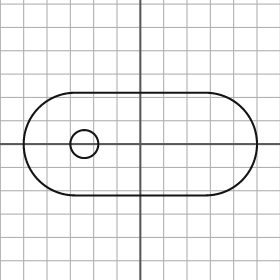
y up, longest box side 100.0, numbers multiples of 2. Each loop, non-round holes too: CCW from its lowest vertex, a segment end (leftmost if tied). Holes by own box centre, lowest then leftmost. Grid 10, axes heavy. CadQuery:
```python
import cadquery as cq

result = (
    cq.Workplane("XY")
    .moveTo(-28.0, -22.0)
    .lineTo(28.0, -22.0)
    .threePointArc((50.0, 0.0), (28.0, 22.0))
    .lineTo(-28.0, 22.0)
    .threePointArc((-50.0, 0.0), (-28.0, -22.0))
    .close()
    .moveTo(-24.0, 0.0)
    .circle(6.0)
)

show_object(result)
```